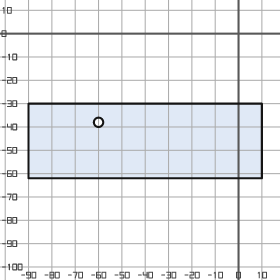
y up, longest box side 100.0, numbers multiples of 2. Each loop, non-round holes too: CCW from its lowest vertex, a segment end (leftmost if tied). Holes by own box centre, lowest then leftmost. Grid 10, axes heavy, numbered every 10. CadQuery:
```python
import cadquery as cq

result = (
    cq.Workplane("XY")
    .moveTo(-90.0, -62.0)
    .lineTo(10.0, -62.0)
    .lineTo(10.0, -30.0)
    .lineTo(-90.0, -30.0)
    .close()
    .moveTo(-60.0, -38.0)
    .circle(2.0)
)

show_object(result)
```